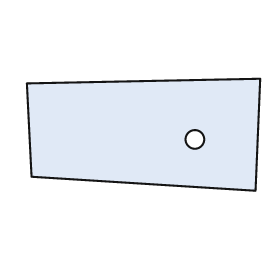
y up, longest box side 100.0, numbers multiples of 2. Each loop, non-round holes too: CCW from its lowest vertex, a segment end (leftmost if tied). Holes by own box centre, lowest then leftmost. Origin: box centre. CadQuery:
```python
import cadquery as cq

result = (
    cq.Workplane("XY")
    .moveTo(48.0, -24.0)
    .lineTo(50.0, 24.0)
    .lineTo(-50.0, 22.0)
    .lineTo(-48.0, -18.0)
    .close()
    .moveTo(22.0, -2.0)
    .circle(4.0)
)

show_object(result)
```